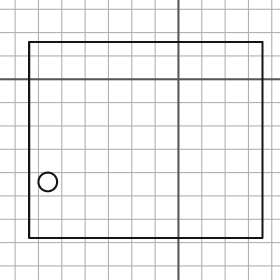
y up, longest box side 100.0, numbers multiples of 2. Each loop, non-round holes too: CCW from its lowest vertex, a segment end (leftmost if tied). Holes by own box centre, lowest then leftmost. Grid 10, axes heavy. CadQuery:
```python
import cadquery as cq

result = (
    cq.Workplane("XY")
    .moveTo(-64.0, -68.0)
    .lineTo(36.0, -68.0)
    .lineTo(36.0, 16.0)
    .lineTo(-64.0, 16.0)
    .close()
    .moveTo(-56.0, -44.0)
    .circle(4.0)
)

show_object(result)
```